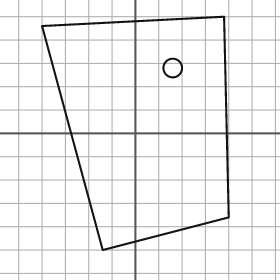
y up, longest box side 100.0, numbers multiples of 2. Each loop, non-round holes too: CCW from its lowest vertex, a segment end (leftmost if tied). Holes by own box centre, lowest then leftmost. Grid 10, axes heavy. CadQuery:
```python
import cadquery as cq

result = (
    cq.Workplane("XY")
    .moveTo(-14.0, -50.0)
    .lineTo(40.0, -36.0)
    .lineTo(38.0, 50.0)
    .lineTo(-40.0, 46.0)
    .close()
    .moveTo(16.0, 28.0)
    .circle(4.0)
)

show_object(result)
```